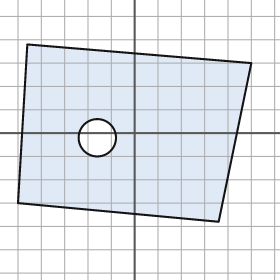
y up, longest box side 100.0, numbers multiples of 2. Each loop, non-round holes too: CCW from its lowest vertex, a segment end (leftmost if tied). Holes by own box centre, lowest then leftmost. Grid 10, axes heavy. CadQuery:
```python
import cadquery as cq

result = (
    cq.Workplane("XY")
    .moveTo(36.0, -38.0)
    .lineTo(50.0, 30.0)
    .lineTo(-46.0, 38.0)
    .lineTo(-50.0, -30.0)
    .close()
    .moveTo(-16.0, -2.0)
    .circle(8.0)
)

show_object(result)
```